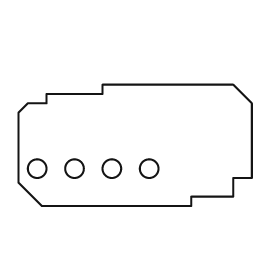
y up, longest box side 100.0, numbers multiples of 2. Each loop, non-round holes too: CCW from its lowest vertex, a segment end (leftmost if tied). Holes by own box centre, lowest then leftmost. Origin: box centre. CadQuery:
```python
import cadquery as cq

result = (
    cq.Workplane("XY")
    .moveTo(-40.0, -26.0)
    .lineTo(24.0, -26.0)
    .lineTo(24.0, -22.0)
    .lineTo(42.0, -22.0)
    .lineTo(42.0, -14.0)
    .lineTo(50.0, -14.0)
    .lineTo(50.0, 18.0)
    .lineTo(42.0, 26.0)
    .lineTo(-14.0, 26.0)
    .lineTo(-14.0, 22.0)
    .lineTo(-38.0, 22.0)
    .lineTo(-38.0, 18.0)
    .lineTo(-46.0, 18.0)
    .lineTo(-50.0, 14.0)
    .lineTo(-50.0, -16.0)
    .close()
    .moveTo(-42.0, -10.0)
    .circle(4.0)
    .moveTo(-26.0, -10.0)
    .circle(4.0)
    .moveTo(-10.0, -10.0)
    .circle(4.0)
    .moveTo(6.0, -10.0)
    .circle(4.0)
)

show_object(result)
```